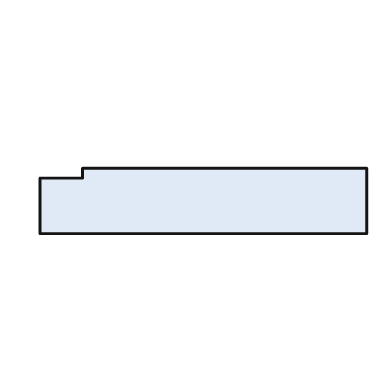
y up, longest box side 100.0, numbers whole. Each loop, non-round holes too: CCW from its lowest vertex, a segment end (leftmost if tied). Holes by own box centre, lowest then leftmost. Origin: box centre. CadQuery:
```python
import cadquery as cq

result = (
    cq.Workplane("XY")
    .moveTo(-50.0, -10.0)
    .lineTo(50.0, -10.0)
    .lineTo(50.0, 10.0)
    .lineTo(-37.0, 10.0)
    .lineTo(-37.0, 7.0)
    .lineTo(-50.0, 7.0)
    .close()
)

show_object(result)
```